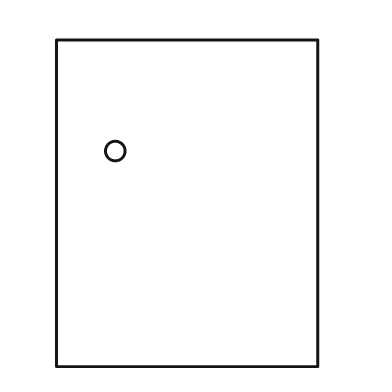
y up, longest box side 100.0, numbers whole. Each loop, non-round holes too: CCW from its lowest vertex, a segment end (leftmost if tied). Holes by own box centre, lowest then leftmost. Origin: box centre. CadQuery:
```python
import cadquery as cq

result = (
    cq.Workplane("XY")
    .moveTo(-40.0, -50.0)
    .lineTo(40.0, -50.0)
    .lineTo(40.0, 50.0)
    .lineTo(-40.0, 50.0)
    .close()
    .moveTo(-22.0, 16.0)
    .circle(3.0)
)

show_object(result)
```